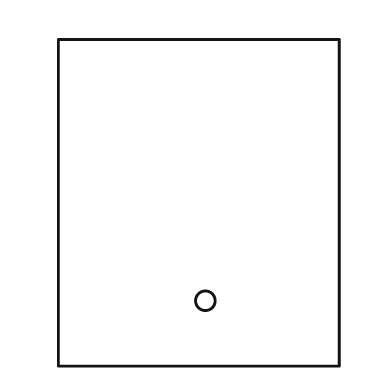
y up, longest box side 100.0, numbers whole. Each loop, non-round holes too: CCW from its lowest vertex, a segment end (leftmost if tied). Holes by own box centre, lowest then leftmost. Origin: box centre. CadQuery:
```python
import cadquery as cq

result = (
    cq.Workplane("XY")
    .moveTo(-43.0, -50.0)
    .lineTo(43.0, -50.0)
    .lineTo(43.0, 50.0)
    .lineTo(-43.0, 50.0)
    .close()
    .moveTo(2.0, -30.0)
    .circle(3.0)
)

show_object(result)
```